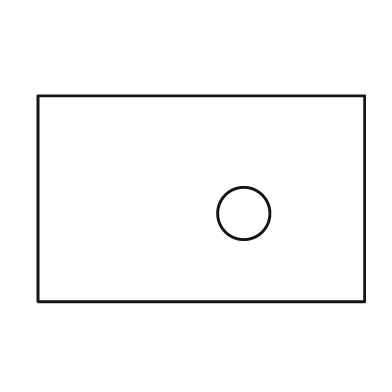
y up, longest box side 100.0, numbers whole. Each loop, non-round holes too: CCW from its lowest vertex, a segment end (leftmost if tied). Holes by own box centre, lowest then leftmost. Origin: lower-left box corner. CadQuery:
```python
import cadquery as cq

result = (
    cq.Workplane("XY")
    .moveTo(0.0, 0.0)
    .lineTo(100.0, 0.0)
    .lineTo(100.0, 63.0)
    .lineTo(0.0, 63.0)
    .close()
    .moveTo(63.0, 27.0)
    .circle(8.0)
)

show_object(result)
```